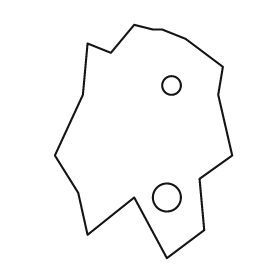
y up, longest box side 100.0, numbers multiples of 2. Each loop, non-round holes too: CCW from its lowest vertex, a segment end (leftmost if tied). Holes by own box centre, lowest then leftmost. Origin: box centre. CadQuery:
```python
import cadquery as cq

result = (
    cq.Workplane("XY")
    .moveTo(10.0, -50.0)
    .lineTo(26.0, -38.0)
    .lineTo(24.0, -16.0)
    .lineTo(38.0, -6.0)
    .lineTo(32.0, 20.0)
    .lineTo(34.0, 32.0)
    .lineTo(18.0, 44.0)
    .lineTo(8.0, 48.0)
    .lineTo(4.0, 48.0)
    .lineTo(-4.0, 50.0)
    .lineTo(-14.0, 38.0)
    .lineTo(-24.0, 42.0)
    .lineTo(-26.0, 20.0)
    .lineTo(-38.0, -6.0)
    .lineTo(-28.0, -22.0)
    .lineTo(-24.0, -40.0)
    .lineTo(-4.0, -24.0)
    .close()
    .moveTo(10.0, -24.0)
    .circle(6.0)
    .moveTo(12.0, 24.0)
    .circle(4.0)
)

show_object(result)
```